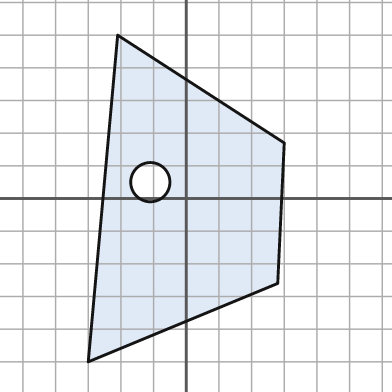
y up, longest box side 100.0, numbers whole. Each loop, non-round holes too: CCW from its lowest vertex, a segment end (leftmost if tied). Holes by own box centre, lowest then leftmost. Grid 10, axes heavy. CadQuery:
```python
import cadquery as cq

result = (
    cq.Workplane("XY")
    .moveTo(-30.0, -50.0)
    .lineTo(28.0, -26.0)
    .lineTo(30.0, 17.0)
    .lineTo(-21.0, 50.0)
    .close()
    .moveTo(-11.0, 5.0)
    .circle(6.0)
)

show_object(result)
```